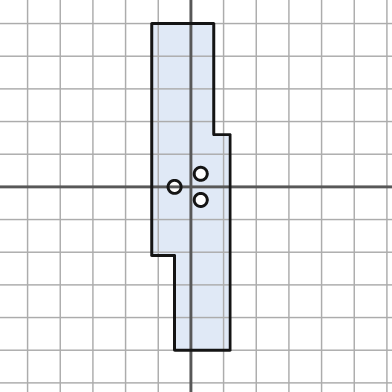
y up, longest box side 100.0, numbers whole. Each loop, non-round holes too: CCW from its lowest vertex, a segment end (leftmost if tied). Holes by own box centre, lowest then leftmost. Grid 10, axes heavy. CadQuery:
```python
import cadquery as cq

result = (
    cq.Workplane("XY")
    .moveTo(-5.0, -50.0)
    .lineTo(12.0, -50.0)
    .lineTo(12.0, 16.0)
    .lineTo(7.0, 16.0)
    .lineTo(7.0, 50.0)
    .lineTo(-12.0, 50.0)
    .lineTo(-12.0, -21.0)
    .lineTo(-5.0, -21.0)
    .close()
    .moveTo(3.0, -4.0)
    .circle(2.0)
    .moveTo(-5.0, 0.0)
    .circle(2.0)
    .moveTo(3.0, 4.0)
    .circle(2.0)
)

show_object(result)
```